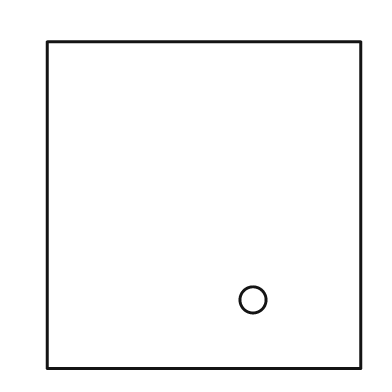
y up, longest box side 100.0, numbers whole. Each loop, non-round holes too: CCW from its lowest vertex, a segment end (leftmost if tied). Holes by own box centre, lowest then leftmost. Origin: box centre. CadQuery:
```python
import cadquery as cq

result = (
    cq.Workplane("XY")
    .moveTo(-48.0, -50.0)
    .lineTo(48.0, -50.0)
    .lineTo(48.0, 50.0)
    .lineTo(-48.0, 50.0)
    .close()
    .moveTo(15.0, -29.0)
    .circle(4.0)
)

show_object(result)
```